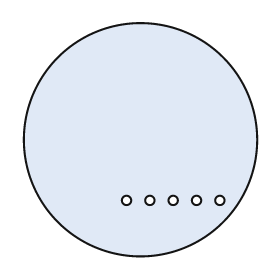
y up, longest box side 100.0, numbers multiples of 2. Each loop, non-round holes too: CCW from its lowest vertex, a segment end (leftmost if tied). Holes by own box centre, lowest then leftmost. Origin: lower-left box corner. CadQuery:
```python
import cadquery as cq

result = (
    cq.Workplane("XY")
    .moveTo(50.0, 50.0)
    .circle(50.0)
    .moveTo(44.0, 24.0)
    .circle(2.0)
    .moveTo(54.0, 24.0)
    .circle(2.0)
    .moveTo(64.0, 24.0)
    .circle(2.0)
    .moveTo(74.0, 24.0)
    .circle(2.0)
    .moveTo(84.0, 24.0)
    .circle(2.0)
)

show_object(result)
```